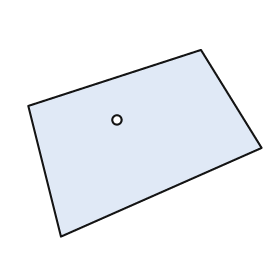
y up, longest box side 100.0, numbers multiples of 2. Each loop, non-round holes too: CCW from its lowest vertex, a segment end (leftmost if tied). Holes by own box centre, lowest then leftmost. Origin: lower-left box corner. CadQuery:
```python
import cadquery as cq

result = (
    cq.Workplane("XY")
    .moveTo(14.0, 0.0)
    .lineTo(100.0, 38.0)
    .lineTo(74.0, 80.0)
    .lineTo(0.0, 56.0)
    .close()
    .moveTo(38.0, 50.0)
    .circle(2.0)
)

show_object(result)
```